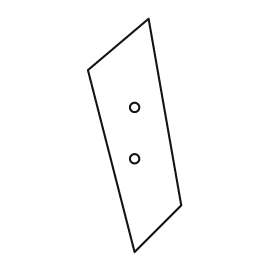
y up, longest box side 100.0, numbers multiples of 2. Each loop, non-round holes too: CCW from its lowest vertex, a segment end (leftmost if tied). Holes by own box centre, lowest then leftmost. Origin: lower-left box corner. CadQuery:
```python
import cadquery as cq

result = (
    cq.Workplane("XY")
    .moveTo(20.0, 0.0)
    .lineTo(40.0, 20.0)
    .lineTo(26.0, 100.0)
    .lineTo(0.0, 78.0)
    .close()
    .moveTo(20.0, 40.0)
    .circle(2.0)
    .moveTo(20.0, 62.0)
    .circle(2.0)
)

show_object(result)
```